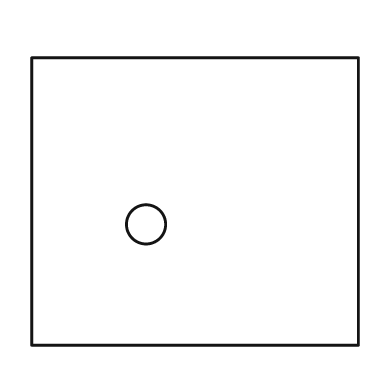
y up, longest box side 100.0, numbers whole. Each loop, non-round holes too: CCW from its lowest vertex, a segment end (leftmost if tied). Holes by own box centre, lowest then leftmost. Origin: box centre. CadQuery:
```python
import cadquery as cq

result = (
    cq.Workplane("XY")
    .moveTo(-50.0, -44.0)
    .lineTo(50.0, -44.0)
    .lineTo(50.0, 44.0)
    .lineTo(-50.0, 44.0)
    .close()
    .moveTo(-15.0, -7.0)
    .circle(6.0)
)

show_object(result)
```